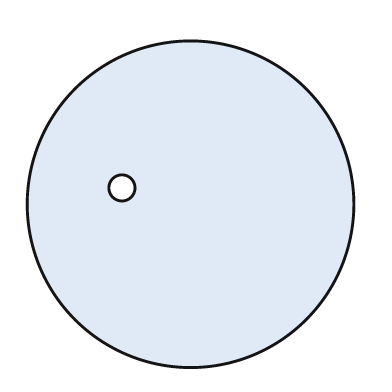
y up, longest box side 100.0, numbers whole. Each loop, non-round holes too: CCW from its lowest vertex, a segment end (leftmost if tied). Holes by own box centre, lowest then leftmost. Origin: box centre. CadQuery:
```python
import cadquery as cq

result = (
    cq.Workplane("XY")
    .moveTo(0.0, 0.0)
    .circle(50.0)
    .moveTo(-21.0, 5.0)
    .circle(4.0)
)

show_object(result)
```